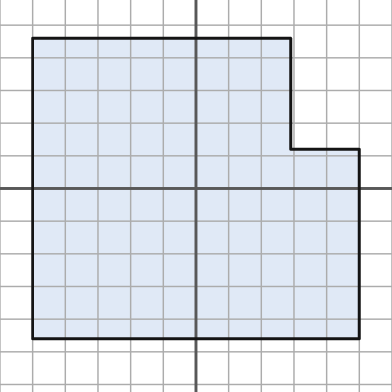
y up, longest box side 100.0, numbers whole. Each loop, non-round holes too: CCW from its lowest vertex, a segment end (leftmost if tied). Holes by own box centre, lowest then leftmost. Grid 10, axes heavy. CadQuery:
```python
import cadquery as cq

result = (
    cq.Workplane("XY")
    .moveTo(-50.0, -46.0)
    .lineTo(50.0, -46.0)
    .lineTo(50.0, 12.0)
    .lineTo(29.0, 12.0)
    .lineTo(29.0, 46.0)
    .lineTo(-50.0, 46.0)
    .close()
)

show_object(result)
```